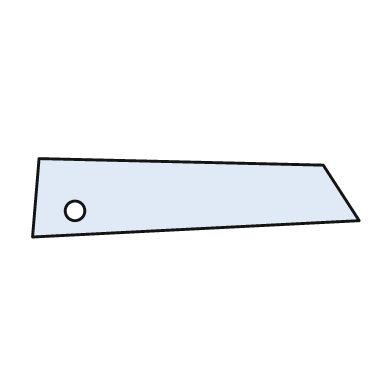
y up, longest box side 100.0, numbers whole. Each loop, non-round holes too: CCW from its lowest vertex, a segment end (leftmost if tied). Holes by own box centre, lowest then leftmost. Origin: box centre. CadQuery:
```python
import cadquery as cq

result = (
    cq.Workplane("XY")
    .moveTo(-50.0, -12.0)
    .lineTo(50.0, -7.0)
    .lineTo(39.0, 10.0)
    .lineTo(-48.0, 12.0)
    .close()
    .moveTo(-37.0, -4.0)
    .circle(3.0)
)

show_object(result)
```